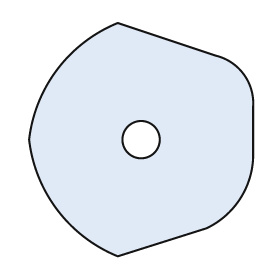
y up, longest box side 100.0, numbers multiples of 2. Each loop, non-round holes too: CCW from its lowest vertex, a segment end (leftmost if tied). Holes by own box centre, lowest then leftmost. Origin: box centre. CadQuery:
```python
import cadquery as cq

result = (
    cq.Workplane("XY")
    .moveTo(-10.0, -50.0)
    .lineTo(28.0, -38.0)
    .threePointArc((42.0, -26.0), (48.0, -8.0))
    .lineTo(48.0, 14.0)
    .threePointArc((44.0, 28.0), (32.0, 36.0))
    .lineTo(-10.0, 50.0)
    .threePointArc((-36.0, 30.0), (-48.0, 0.0))
    .threePointArc((-36.0, -30.0), (-10.0, -50.0))
    .close()
    .moveTo(0.0, 0.0)
    .circle(8.0)
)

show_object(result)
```